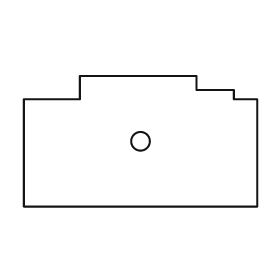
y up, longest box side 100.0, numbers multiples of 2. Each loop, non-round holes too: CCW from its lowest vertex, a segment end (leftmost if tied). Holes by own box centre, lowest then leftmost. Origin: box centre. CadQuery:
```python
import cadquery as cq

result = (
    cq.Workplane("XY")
    .moveTo(-50.0, -28.0)
    .lineTo(50.0, -28.0)
    .lineTo(50.0, 18.0)
    .lineTo(40.0, 18.0)
    .lineTo(40.0, 22.0)
    .lineTo(24.0, 22.0)
    .lineTo(24.0, 28.0)
    .lineTo(-26.0, 28.0)
    .lineTo(-26.0, 18.0)
    .lineTo(-50.0, 18.0)
    .close()
    .moveTo(0.0, 0.0)
    .circle(4.0)
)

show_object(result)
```